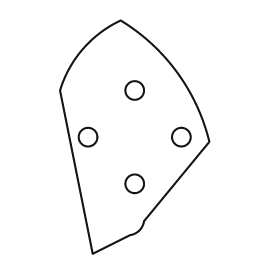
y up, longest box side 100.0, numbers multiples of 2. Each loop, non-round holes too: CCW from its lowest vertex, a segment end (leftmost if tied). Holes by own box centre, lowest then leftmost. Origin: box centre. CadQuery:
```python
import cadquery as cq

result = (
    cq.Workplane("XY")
    .moveTo(-18.0, -50.0)
    .lineTo(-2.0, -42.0)
    .threePointArc((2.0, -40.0), (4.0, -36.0))
    .lineTo(32.0, -2.0)
    .threePointArc((18.0, 28.0), (-6.0, 50.0))
    .threePointArc((-22.0, 38.0), (-32.0, 20.0))
    .close()
    .moveTo(0.0, -20.0)
    .circle(4.0)
    .moveTo(-20.0, 0.0)
    .circle(4.0)
    .moveTo(20.0, 0.0)
    .circle(4.0)
    .moveTo(0.0, 20.0)
    .circle(4.0)
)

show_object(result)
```